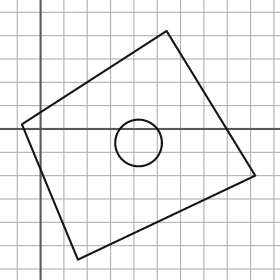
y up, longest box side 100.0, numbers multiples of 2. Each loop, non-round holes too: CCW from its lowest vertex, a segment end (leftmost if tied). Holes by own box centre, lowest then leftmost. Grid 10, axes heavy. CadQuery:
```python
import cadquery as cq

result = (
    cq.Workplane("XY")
    .moveTo(16.0, -56.0)
    .lineTo(92.0, -20.0)
    .lineTo(54.0, 42.0)
    .lineTo(-8.0, 2.0)
    .close()
    .moveTo(42.0, -6.0)
    .circle(10.0)
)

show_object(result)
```